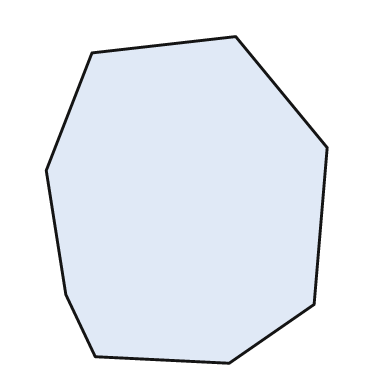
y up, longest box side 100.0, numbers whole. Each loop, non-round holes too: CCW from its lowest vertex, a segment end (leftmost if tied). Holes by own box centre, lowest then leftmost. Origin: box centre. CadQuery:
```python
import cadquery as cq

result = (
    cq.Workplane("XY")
    .moveTo(13.0, -50.0)
    .lineTo(39.0, -32.0)
    .lineTo(43.0, 16.0)
    .lineTo(15.0, 50.0)
    .lineTo(-29.0, 45.0)
    .lineTo(-43.0, 9.0)
    .lineTo(-37.0, -29.0)
    .lineTo(-28.0, -48.0)
    .close()
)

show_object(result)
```